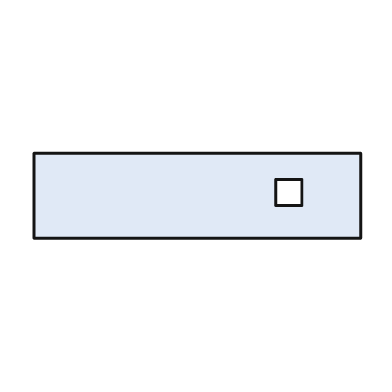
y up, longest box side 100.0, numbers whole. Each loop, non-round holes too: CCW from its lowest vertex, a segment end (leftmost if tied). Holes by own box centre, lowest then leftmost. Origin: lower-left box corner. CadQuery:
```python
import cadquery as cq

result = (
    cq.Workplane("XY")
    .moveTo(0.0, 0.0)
    .lineTo(100.0, 0.0)
    .lineTo(100.0, 26.0)
    .lineTo(0.0, 26.0)
    .close()
    .moveTo(74.0, 10.0)
    .lineTo(82.0, 10.0)
    .lineTo(82.0, 18.0)
    .lineTo(74.0, 18.0)
    .close()
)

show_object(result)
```